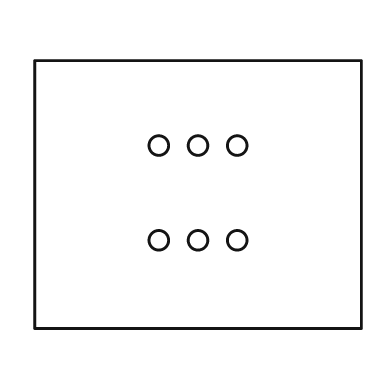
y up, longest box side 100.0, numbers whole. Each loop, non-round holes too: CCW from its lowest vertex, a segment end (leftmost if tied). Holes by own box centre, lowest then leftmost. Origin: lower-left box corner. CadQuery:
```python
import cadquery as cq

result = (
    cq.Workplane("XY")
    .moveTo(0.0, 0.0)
    .lineTo(100.0, 0.0)
    .lineTo(100.0, 82.0)
    .lineTo(0.0, 82.0)
    .close()
    .moveTo(38.0, 27.0)
    .circle(3.0)
    .moveTo(50.0, 27.0)
    .circle(3.0)
    .moveTo(62.0, 27.0)
    .circle(3.0)
    .moveTo(38.0, 56.0)
    .circle(3.0)
    .moveTo(50.0, 56.0)
    .circle(3.0)
    .moveTo(62.0, 56.0)
    .circle(3.0)
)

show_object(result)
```